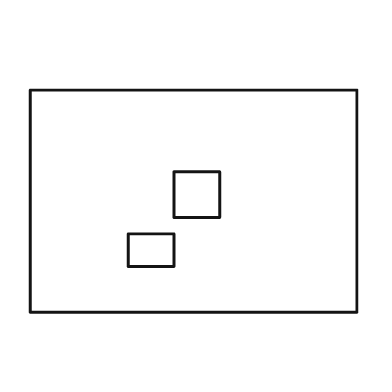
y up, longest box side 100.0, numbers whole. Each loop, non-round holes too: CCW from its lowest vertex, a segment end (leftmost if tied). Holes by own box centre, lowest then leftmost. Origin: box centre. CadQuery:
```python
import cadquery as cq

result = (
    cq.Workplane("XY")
    .moveTo(-50.0, -34.0)
    .lineTo(50.0, -34.0)
    .lineTo(50.0, 34.0)
    .lineTo(-50.0, 34.0)
    .close()
    .moveTo(-20.0, -20.0)
    .lineTo(-6.0, -20.0)
    .lineTo(-6.0, -10.0)
    .lineTo(-20.0, -10.0)
    .close()
    .moveTo(-6.0, -5.0)
    .lineTo(8.0, -5.0)
    .lineTo(8.0, 9.0)
    .lineTo(-6.0, 9.0)
    .close()
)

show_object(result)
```